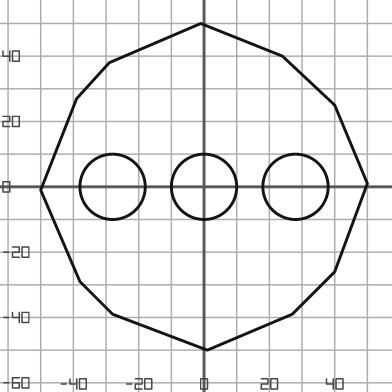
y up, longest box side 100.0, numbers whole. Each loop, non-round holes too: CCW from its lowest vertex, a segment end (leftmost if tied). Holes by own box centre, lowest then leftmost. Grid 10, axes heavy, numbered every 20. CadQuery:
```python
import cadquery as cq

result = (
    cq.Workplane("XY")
    .moveTo(1.0, -50.0)
    .lineTo(27.0, -39.0)
    .lineTo(40.0, -26.0)
    .lineTo(50.0, 1.0)
    .lineTo(40.0, 25.0)
    .lineTo(24.0, 40.0)
    .lineTo(-1.0, 50.0)
    .lineTo(-29.0, 38.0)
    .lineTo(-39.0, 27.0)
    .lineTo(-50.0, -1.0)
    .lineTo(-38.0, -29.0)
    .lineTo(-28.0, -39.0)
    .close()
    .moveTo(-28.0, 0.0)
    .circle(10.0)
    .moveTo(0.0, 0.0)
    .circle(10.0)
    .moveTo(28.0, 0.0)
    .circle(10.0)
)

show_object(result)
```